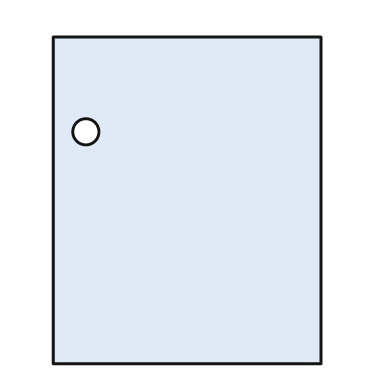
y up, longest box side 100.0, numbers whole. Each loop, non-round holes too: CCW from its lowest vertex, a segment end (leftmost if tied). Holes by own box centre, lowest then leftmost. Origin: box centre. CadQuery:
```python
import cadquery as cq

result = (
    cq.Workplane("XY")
    .moveTo(-41.0, -50.0)
    .lineTo(41.0, -50.0)
    .lineTo(41.0, 50.0)
    .lineTo(-41.0, 50.0)
    .close()
    .moveTo(-31.0, 21.0)
    .circle(4.0)
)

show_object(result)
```